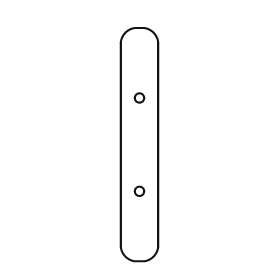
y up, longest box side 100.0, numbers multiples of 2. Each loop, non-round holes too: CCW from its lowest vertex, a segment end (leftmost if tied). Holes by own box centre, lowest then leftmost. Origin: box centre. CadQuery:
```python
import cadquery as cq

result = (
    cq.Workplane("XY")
    .moveTo(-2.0, -50.0)
    .lineTo(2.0, -50.0)
    .threePointArc((6.0, -48.0), (8.0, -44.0))
    .lineTo(8.0, 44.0)
    .threePointArc((6.0, 48.0), (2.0, 50.0))
    .lineTo(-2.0, 50.0)
    .threePointArc((-6.0, 48.0), (-8.0, 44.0))
    .lineTo(-8.0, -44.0)
    .threePointArc((-6.0, -48.0), (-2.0, -50.0))
    .close()
    .moveTo(0.0, -20.0)
    .circle(2.0)
    .moveTo(0.0, 20.0)
    .circle(2.0)
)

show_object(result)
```